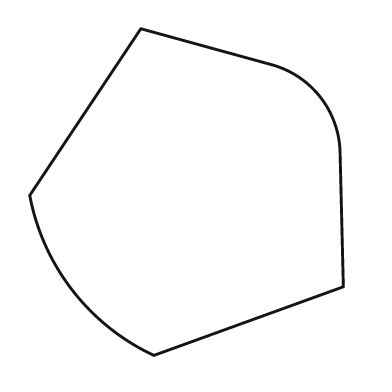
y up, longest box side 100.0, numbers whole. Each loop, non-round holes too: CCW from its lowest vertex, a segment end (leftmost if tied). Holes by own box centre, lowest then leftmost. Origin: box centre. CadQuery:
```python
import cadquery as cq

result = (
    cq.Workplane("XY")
    .moveTo(-10.0, -50.0)
    .lineTo(48.0, -29.0)
    .lineTo(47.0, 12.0)
    .threePointArc((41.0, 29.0), (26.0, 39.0))
    .lineTo(-14.0, 50.0)
    .lineTo(-48.0, -1.0)
    .threePointArc((-35.0, -30.0), (-10.0, -50.0))
    .close()
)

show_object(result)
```